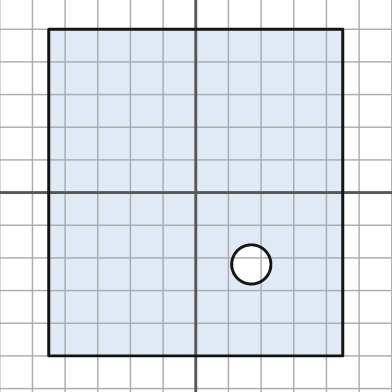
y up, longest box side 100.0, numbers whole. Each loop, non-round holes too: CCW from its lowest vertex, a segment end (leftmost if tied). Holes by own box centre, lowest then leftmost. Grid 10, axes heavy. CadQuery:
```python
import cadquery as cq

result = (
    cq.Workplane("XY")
    .moveTo(-45.0, -50.0)
    .lineTo(45.0, -50.0)
    .lineTo(45.0, 50.0)
    .lineTo(-45.0, 50.0)
    .close()
    .moveTo(17.0, -22.0)
    .circle(6.0)
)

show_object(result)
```